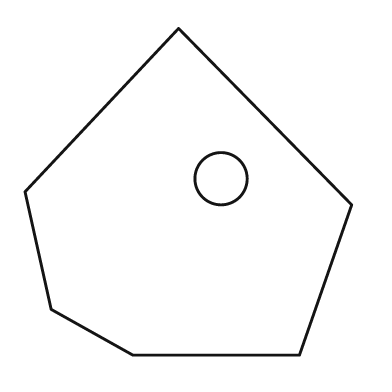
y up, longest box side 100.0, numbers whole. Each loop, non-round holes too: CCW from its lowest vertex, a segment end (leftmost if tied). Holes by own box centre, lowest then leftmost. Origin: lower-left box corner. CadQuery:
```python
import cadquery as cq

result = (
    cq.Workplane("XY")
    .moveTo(33.0, 0.0)
    .lineTo(84.0, 0.0)
    .lineTo(100.0, 46.0)
    .lineTo(47.0, 100.0)
    .lineTo(0.0, 50.0)
    .lineTo(8.0, 14.0)
    .close()
    .moveTo(60.0, 54.0)
    .circle(8.0)
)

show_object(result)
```